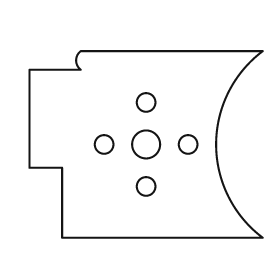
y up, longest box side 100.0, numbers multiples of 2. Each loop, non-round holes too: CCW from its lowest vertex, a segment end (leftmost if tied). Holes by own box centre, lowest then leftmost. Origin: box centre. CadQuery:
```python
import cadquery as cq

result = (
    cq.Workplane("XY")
    .moveTo(-36.0, -40.0)
    .lineTo(50.0, -40.0)
    .threePointArc((30.0, 0.0), (50.0, 40.0))
    .lineTo(-28.0, 40.0)
    .threePointArc((-30.0, 36.0), (-28.0, 32.0))
    .lineTo(-50.0, 32.0)
    .lineTo(-50.0, -10.0)
    .lineTo(-36.0, -10.0)
    .close()
    .moveTo(0.0, -18.0)
    .circle(4.0)
    .moveTo(-18.0, 0.0)
    .circle(4.0)
    .moveTo(0.0, 0.0)
    .circle(6.0)
    .moveTo(18.0, 0.0)
    .circle(4.0)
    .moveTo(0.0, 18.0)
    .circle(4.0)
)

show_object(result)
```